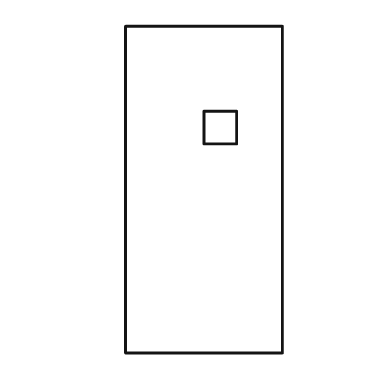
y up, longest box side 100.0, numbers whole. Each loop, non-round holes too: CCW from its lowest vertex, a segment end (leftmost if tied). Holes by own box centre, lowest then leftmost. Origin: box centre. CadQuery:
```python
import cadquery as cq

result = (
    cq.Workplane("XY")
    .moveTo(-24.0, -50.0)
    .lineTo(24.0, -50.0)
    .lineTo(24.0, 50.0)
    .lineTo(-24.0, 50.0)
    .close()
    .moveTo(0.0, 14.0)
    .lineTo(10.0, 14.0)
    .lineTo(10.0, 24.0)
    .lineTo(0.0, 24.0)
    .close()
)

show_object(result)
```